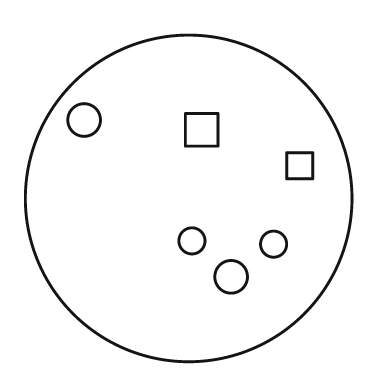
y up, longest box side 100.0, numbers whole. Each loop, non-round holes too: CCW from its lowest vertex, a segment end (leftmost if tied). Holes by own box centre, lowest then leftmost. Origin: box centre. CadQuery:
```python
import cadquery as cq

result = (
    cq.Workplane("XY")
    .moveTo(0.0, 0.0)
    .circle(50.0)
    .moveTo(13.0, -24.0)
    .circle(5.0)
    .moveTo(26.0, -14.0)
    .circle(4.0)
    .moveTo(1.0, -13.0)
    .circle(4.0)
    .moveTo(30.0, 6.0)
    .lineTo(38.0, 6.0)
    .lineTo(38.0, 14.0)
    .lineTo(30.0, 14.0)
    .close()
    .moveTo(-1.0, 16.0)
    .lineTo(9.0, 16.0)
    .lineTo(9.0, 26.0)
    .lineTo(-1.0, 26.0)
    .close()
    .moveTo(-32.0, 24.0)
    .circle(5.0)
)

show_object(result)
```